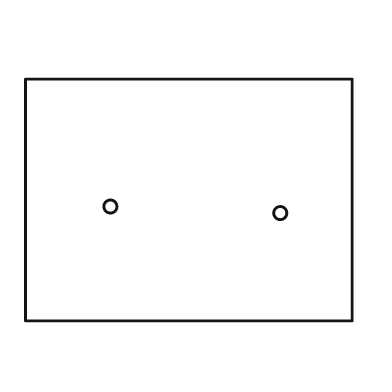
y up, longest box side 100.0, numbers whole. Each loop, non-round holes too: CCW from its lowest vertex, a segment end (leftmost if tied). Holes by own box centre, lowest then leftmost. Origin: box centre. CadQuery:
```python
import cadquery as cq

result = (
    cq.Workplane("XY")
    .moveTo(-50.0, -37.0)
    .lineTo(50.0, -37.0)
    .lineTo(50.0, 37.0)
    .lineTo(-50.0, 37.0)
    .close()
    .moveTo(28.0, -4.0)
    .circle(2.0)
    .moveTo(-24.0, -2.0)
    .circle(2.0)
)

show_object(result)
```